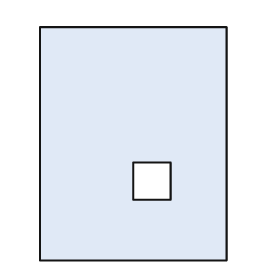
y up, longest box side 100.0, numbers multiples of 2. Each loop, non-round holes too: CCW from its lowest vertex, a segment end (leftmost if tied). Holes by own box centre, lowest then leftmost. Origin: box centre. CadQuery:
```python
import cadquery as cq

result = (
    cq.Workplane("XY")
    .moveTo(-40.0, -50.0)
    .lineTo(40.0, -50.0)
    .lineTo(40.0, 50.0)
    .lineTo(-40.0, 50.0)
    .close()
    .moveTo(0.0, -24.0)
    .lineTo(16.0, -24.0)
    .lineTo(16.0, -8.0)
    .lineTo(0.0, -8.0)
    .close()
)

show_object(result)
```